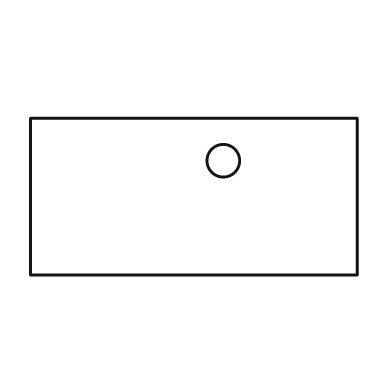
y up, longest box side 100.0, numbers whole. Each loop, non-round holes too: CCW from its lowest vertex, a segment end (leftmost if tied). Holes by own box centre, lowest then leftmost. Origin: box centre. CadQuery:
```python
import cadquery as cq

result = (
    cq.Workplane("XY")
    .moveTo(-50.0, -24.0)
    .lineTo(50.0, -24.0)
    .lineTo(50.0, 24.0)
    .lineTo(-50.0, 24.0)
    .close()
    .moveTo(9.0, 11.0)
    .circle(5.0)
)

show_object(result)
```